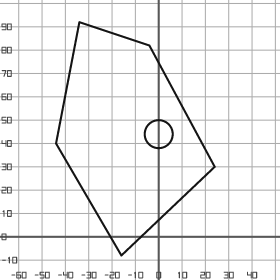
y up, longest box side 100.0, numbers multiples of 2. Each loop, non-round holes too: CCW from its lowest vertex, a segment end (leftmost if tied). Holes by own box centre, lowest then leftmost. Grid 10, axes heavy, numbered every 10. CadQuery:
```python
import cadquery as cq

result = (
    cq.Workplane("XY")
    .moveTo(-16.0, -8.0)
    .lineTo(24.0, 30.0)
    .lineTo(-4.0, 82.0)
    .lineTo(-34.0, 92.0)
    .lineTo(-44.0, 40.0)
    .close()
    .moveTo(0.0, 44.0)
    .circle(6.0)
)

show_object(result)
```